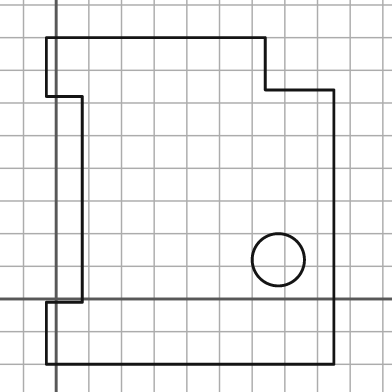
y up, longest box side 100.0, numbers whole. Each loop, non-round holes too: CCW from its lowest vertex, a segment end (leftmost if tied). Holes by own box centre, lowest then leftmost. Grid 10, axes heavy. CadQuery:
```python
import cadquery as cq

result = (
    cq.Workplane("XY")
    .moveTo(-3.0, -20.0)
    .lineTo(85.0, -20.0)
    .lineTo(85.0, 64.0)
    .lineTo(64.0, 64.0)
    .lineTo(64.0, 80.0)
    .lineTo(-3.0, 80.0)
    .lineTo(-3.0, 62.0)
    .lineTo(8.0, 62.0)
    .lineTo(8.0, -1.0)
    .lineTo(-3.0, -1.0)
    .close()
    .moveTo(68.0, 12.0)
    .circle(8.0)
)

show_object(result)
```